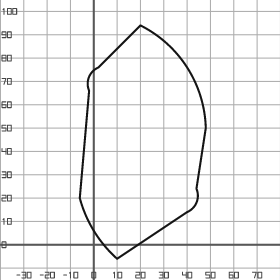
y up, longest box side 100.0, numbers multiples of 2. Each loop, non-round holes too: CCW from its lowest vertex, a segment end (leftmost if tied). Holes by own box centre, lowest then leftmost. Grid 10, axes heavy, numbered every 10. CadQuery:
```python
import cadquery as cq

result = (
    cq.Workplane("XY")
    .moveTo(10.0, -6.0)
    .lineTo(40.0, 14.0)
    .threePointArc((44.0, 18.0), (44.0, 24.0))
    .lineTo(48.0, 50.0)
    .threePointArc((40.0, 76.0), (20.0, 94.0))
    .lineTo(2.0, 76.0)
    .threePointArc((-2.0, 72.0), (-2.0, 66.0))
    .lineTo(-6.0, 20.0)
    .threePointArc((0.0, 6.0), (10.0, -6.0))
    .close()
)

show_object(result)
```